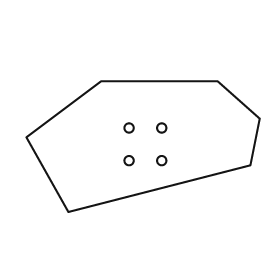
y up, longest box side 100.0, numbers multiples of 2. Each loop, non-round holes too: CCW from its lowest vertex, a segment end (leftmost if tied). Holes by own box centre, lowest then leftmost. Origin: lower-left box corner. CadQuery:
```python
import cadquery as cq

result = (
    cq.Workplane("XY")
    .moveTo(18.0, 0.0)
    .lineTo(96.0, 20.0)
    .lineTo(100.0, 40.0)
    .lineTo(82.0, 56.0)
    .lineTo(32.0, 56.0)
    .lineTo(0.0, 32.0)
    .close()
    .moveTo(44.0, 22.0)
    .circle(2.0)
    .moveTo(58.0, 22.0)
    .circle(2.0)
    .moveTo(44.0, 36.0)
    .circle(2.0)
    .moveTo(58.0, 36.0)
    .circle(2.0)
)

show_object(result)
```